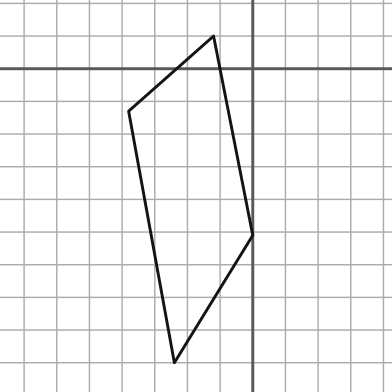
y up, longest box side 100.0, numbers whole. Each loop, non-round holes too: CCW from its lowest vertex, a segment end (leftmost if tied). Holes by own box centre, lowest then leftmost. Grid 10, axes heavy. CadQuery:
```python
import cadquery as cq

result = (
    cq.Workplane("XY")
    .moveTo(-24.0, -90.0)
    .lineTo(0.0, -51.0)
    .lineTo(-12.0, 10.0)
    .lineTo(-38.0, -13.0)
    .close()
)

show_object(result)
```